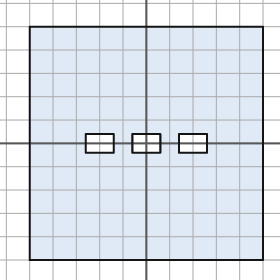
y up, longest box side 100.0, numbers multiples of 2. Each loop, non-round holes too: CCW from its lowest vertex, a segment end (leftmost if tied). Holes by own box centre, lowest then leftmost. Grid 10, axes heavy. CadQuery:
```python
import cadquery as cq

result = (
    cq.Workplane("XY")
    .moveTo(-50.0, -50.0)
    .lineTo(50.0, -50.0)
    .lineTo(50.0, 50.0)
    .lineTo(-50.0, 50.0)
    .close()
    .moveTo(-26.0, -4.0)
    .lineTo(-14.0, -4.0)
    .lineTo(-14.0, 4.0)
    .lineTo(-26.0, 4.0)
    .close()
    .moveTo(-6.0, -4.0)
    .lineTo(6.0, -4.0)
    .lineTo(6.0, 4.0)
    .lineTo(-6.0, 4.0)
    .close()
    .moveTo(14.0, -4.0)
    .lineTo(26.0, -4.0)
    .lineTo(26.0, 4.0)
    .lineTo(14.0, 4.0)
    .close()
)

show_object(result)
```